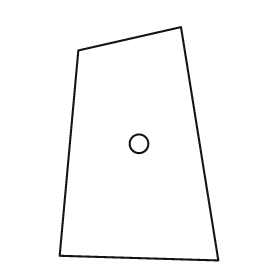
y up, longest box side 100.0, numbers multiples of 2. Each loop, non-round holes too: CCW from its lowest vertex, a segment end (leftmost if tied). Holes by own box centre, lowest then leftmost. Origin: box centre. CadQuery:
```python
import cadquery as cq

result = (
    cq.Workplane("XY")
    .moveTo(34.0, -50.0)
    .lineTo(18.0, 50.0)
    .lineTo(-26.0, 40.0)
    .lineTo(-34.0, -48.0)
    .close()
    .moveTo(0.0, 0.0)
    .circle(4.0)
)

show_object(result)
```